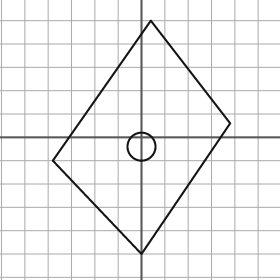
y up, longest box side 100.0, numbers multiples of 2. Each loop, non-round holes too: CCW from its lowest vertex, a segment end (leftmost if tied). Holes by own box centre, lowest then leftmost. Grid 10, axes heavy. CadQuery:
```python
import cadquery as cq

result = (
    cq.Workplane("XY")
    .moveTo(0.0, -50.0)
    .lineTo(38.0, 6.0)
    .lineTo(4.0, 50.0)
    .lineTo(-38.0, -10.0)
    .close()
    .moveTo(0.0, -4.0)
    .circle(6.0)
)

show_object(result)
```